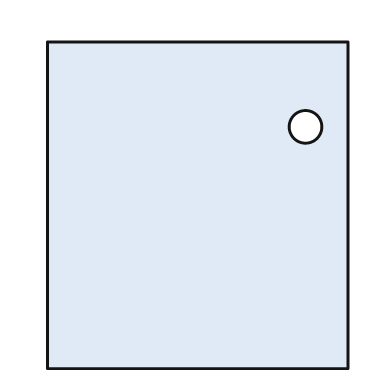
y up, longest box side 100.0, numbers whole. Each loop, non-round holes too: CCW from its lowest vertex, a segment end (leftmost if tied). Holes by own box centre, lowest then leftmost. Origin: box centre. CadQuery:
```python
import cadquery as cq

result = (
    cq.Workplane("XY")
    .moveTo(-46.0, -50.0)
    .lineTo(46.0, -50.0)
    .lineTo(46.0, 50.0)
    .lineTo(-46.0, 50.0)
    .close()
    .moveTo(33.0, 24.0)
    .circle(5.0)
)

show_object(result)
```